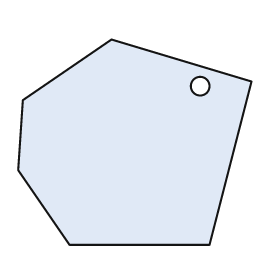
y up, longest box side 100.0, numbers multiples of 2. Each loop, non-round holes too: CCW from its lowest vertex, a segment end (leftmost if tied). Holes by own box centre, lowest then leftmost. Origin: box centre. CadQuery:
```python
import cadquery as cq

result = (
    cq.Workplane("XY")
    .moveTo(-28.0, -44.0)
    .lineTo(32.0, -44.0)
    .lineTo(50.0, 26.0)
    .lineTo(-10.0, 44.0)
    .lineTo(-48.0, 18.0)
    .lineTo(-50.0, -12.0)
    .close()
    .moveTo(28.0, 24.0)
    .circle(4.0)
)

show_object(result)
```